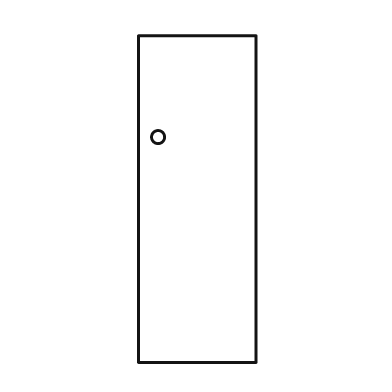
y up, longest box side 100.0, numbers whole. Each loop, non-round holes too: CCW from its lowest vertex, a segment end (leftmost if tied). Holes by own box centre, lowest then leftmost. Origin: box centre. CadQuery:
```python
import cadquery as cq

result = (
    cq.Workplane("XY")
    .moveTo(-18.0, -50.0)
    .lineTo(18.0, -50.0)
    .lineTo(18.0, 50.0)
    .lineTo(-18.0, 50.0)
    .close()
    .moveTo(-12.0, 19.0)
    .circle(2.0)
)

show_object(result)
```